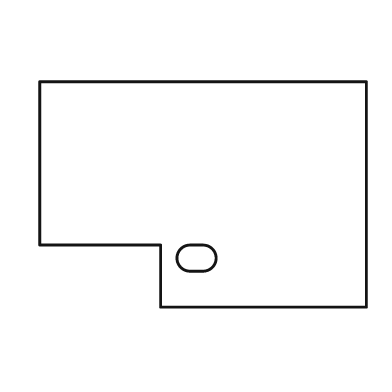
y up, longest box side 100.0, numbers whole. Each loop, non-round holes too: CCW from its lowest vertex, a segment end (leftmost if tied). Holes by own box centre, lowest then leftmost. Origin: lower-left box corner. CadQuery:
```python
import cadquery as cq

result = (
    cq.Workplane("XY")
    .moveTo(37.0, 0.0)
    .lineTo(100.0, 0.0)
    .lineTo(100.0, 69.0)
    .lineTo(0.0, 69.0)
    .lineTo(0.0, 19.0)
    .lineTo(37.0, 19.0)
    .close()
    .moveTo(46.0, 11.0)
    .lineTo(50.0, 11.0)
    .threePointArc((54.0, 15.0), (50.0, 19.0))
    .lineTo(46.0, 19.0)
    .threePointArc((42.0, 15.0), (46.0, 11.0))
    .close()
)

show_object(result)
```